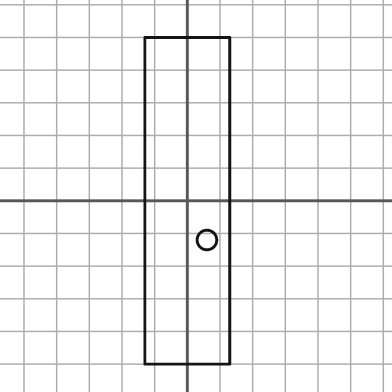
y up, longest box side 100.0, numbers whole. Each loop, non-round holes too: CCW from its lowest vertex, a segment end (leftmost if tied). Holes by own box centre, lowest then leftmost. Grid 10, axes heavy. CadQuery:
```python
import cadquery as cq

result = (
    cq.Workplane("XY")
    .moveTo(-13.0, -50.0)
    .lineTo(13.0, -50.0)
    .lineTo(13.0, 50.0)
    .lineTo(-13.0, 50.0)
    .close()
    .moveTo(6.0, -12.0)
    .circle(3.0)
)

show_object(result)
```